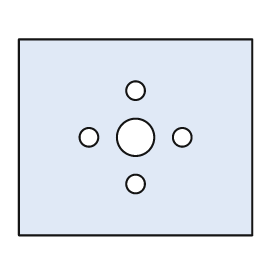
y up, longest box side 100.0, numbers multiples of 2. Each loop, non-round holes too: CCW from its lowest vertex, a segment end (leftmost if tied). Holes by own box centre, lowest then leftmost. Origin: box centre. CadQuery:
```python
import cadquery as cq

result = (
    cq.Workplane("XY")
    .moveTo(-50.0, -42.0)
    .lineTo(50.0, -42.0)
    .lineTo(50.0, 42.0)
    .lineTo(-50.0, 42.0)
    .close()
    .moveTo(0.0, -20.0)
    .circle(4.0)
    .moveTo(-20.0, 0.0)
    .circle(4.0)
    .moveTo(0.0, 0.0)
    .circle(8.0)
    .moveTo(20.0, 0.0)
    .circle(4.0)
    .moveTo(0.0, 20.0)
    .circle(4.0)
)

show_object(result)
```